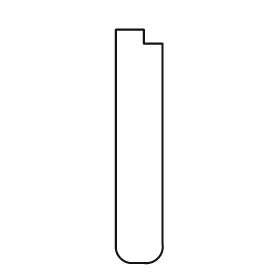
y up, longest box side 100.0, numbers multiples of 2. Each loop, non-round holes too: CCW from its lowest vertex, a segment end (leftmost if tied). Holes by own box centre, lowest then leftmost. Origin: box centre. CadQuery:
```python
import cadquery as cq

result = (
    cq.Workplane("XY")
    .moveTo(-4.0, -50.0)
    .lineTo(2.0, -50.0)
    .threePointArc((8.0, -48.0), (10.0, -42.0))
    .lineTo(10.0, 44.0)
    .lineTo(2.0, 44.0)
    .lineTo(2.0, 50.0)
    .lineTo(-10.0, 50.0)
    .lineTo(-10.0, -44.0)
    .threePointArc((-8.0, -48.0), (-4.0, -50.0))
    .close()
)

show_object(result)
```